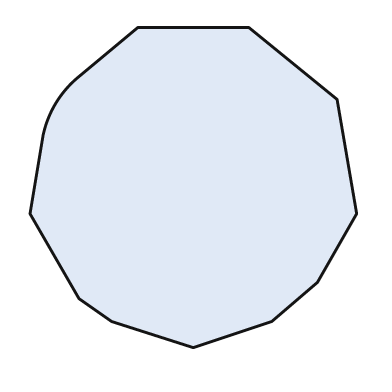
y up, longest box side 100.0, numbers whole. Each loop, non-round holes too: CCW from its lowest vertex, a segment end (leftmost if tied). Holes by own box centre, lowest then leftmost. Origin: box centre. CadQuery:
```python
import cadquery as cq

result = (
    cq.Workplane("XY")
    .moveTo(0.0, -49.0)
    .lineTo(24.0, -41.0)
    .lineTo(38.0, -29.0)
    .lineTo(50.0, -8.0)
    .lineTo(44.0, 27.0)
    .lineTo(17.0, 49.0)
    .lineTo(-17.0, 49.0)
    .lineTo(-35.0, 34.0)
    .threePointArc((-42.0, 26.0), (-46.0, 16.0))
    .lineTo(-50.0, -8.0)
    .lineTo(-35.0, -34.0)
    .lineTo(-25.0, -41.0)
    .close()
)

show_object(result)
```